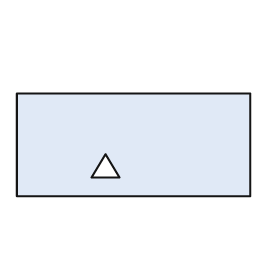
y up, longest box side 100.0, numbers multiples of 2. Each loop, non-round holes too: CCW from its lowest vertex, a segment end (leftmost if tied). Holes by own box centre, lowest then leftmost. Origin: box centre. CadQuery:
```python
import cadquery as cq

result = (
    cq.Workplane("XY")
    .moveTo(-50.0, -22.0)
    .lineTo(50.0, -22.0)
    .lineTo(50.0, 22.0)
    .lineTo(-50.0, 22.0)
    .close()
    .moveTo(-18.0, -14.0)
    .lineTo(-6.0, -14.0)
    .lineTo(-12.0, -4.0)
    .close()
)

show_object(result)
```